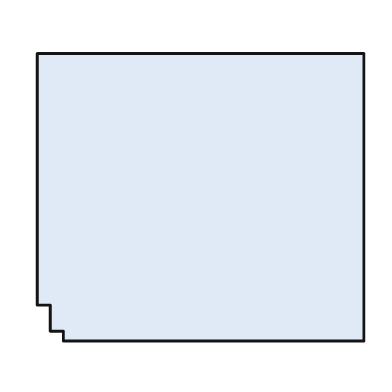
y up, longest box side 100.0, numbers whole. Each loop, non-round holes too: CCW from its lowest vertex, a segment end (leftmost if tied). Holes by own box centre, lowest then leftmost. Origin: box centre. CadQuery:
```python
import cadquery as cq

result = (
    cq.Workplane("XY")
    .moveTo(-42.0, -44.0)
    .lineTo(50.0, -44.0)
    .lineTo(50.0, 44.0)
    .lineTo(-50.0, 44.0)
    .lineTo(-50.0, -33.0)
    .lineTo(-46.0, -33.0)
    .lineTo(-46.0, -41.0)
    .lineTo(-42.0, -41.0)
    .close()
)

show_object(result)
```